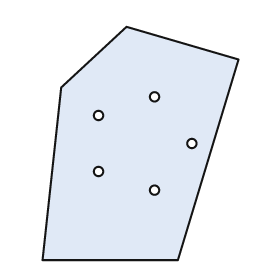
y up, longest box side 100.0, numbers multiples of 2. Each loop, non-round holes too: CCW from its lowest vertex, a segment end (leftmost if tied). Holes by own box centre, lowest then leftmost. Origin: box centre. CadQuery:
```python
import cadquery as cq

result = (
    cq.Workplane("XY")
    .moveTo(-42.0, -50.0)
    .lineTo(16.0, -50.0)
    .lineTo(42.0, 36.0)
    .lineTo(-6.0, 50.0)
    .lineTo(-34.0, 24.0)
    .close()
    .moveTo(6.0, -20.0)
    .circle(2.0)
    .moveTo(-18.0, -12.0)
    .circle(2.0)
    .moveTo(22.0, 0.0)
    .circle(2.0)
    .moveTo(-18.0, 12.0)
    .circle(2.0)
    .moveTo(6.0, 20.0)
    .circle(2.0)
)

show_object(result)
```